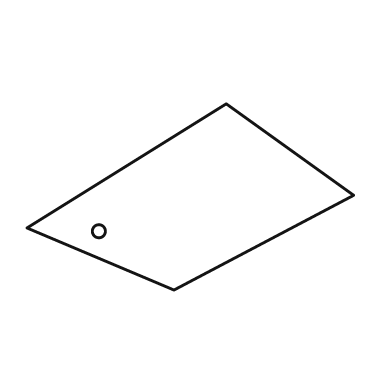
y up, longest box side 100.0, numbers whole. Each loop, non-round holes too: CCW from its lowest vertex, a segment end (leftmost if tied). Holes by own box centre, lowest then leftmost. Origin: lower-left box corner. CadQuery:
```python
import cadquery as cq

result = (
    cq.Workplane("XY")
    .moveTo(45.0, 0.0)
    .lineTo(100.0, 29.0)
    .lineTo(61.0, 57.0)
    .lineTo(0.0, 19.0)
    .close()
    .moveTo(22.0, 18.0)
    .circle(2.0)
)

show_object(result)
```